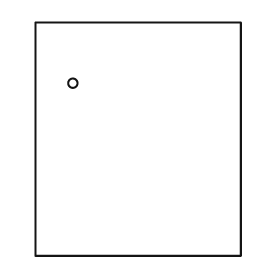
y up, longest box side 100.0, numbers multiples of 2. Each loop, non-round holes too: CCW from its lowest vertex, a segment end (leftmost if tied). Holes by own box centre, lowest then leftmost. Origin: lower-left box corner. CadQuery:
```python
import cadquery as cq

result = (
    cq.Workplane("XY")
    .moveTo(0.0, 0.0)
    .lineTo(88.0, 0.0)
    .lineTo(88.0, 100.0)
    .lineTo(0.0, 100.0)
    .close()
    .moveTo(16.0, 74.0)
    .circle(2.0)
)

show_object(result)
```